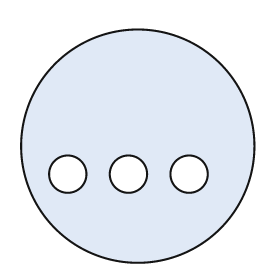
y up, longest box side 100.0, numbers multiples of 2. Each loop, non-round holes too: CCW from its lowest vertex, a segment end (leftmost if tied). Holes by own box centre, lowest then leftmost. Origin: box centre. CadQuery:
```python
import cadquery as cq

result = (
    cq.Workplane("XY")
    .moveTo(0.0, 0.0)
    .circle(50.0)
    .moveTo(-30.0, -12.0)
    .circle(8.0)
    .moveTo(-4.0, -12.0)
    .circle(8.0)
    .moveTo(22.0, -12.0)
    .circle(8.0)
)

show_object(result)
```